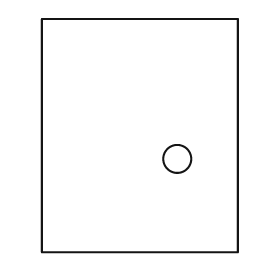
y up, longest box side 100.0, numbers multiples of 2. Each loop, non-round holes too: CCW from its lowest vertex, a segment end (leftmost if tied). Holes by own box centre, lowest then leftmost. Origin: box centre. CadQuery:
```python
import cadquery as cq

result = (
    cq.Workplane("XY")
    .moveTo(-42.0, -50.0)
    .lineTo(42.0, -50.0)
    .lineTo(42.0, 50.0)
    .lineTo(-42.0, 50.0)
    .close()
    .moveTo(16.0, -10.0)
    .circle(6.0)
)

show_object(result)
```